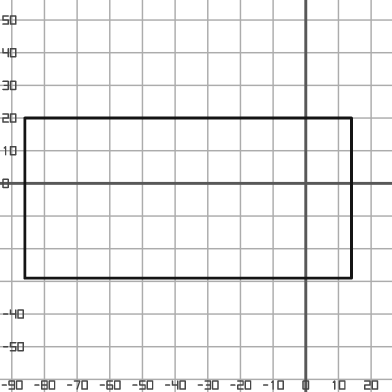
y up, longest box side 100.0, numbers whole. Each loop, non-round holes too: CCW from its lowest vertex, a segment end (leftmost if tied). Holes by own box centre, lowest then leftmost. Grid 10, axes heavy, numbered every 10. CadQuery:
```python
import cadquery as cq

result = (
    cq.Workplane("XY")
    .moveTo(-86.0, -29.0)
    .lineTo(14.0, -29.0)
    .lineTo(14.0, 20.0)
    .lineTo(-86.0, 20.0)
    .close()
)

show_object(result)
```